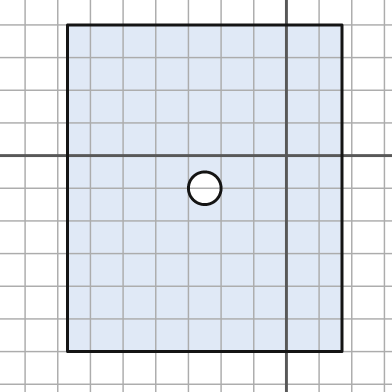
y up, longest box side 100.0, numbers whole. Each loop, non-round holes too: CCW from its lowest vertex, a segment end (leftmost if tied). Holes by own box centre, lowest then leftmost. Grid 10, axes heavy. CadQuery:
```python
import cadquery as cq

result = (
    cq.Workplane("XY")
    .moveTo(-67.0, -60.0)
    .lineTo(17.0, -60.0)
    .lineTo(17.0, 40.0)
    .lineTo(-67.0, 40.0)
    .close()
    .moveTo(-25.0, -10.0)
    .circle(5.0)
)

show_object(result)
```